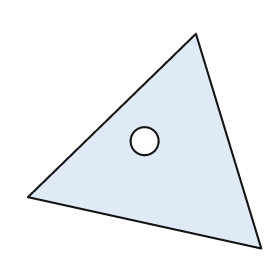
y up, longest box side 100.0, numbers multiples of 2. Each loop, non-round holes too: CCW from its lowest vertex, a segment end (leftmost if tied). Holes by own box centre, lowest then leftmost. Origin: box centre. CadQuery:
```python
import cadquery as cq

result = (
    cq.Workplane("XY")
    .moveTo(50.0, -46.0)
    .lineTo(22.0, 46.0)
    .lineTo(-50.0, -24.0)
    .close()
    .moveTo(0.0, 0.0)
    .circle(6.0)
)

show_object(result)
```